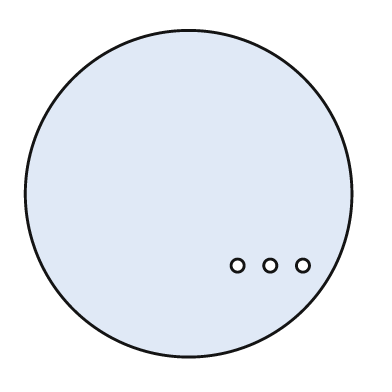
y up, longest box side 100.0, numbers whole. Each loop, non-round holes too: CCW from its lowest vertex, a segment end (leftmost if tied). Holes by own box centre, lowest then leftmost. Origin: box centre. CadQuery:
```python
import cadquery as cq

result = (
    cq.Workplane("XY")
    .moveTo(0.0, 0.0)
    .circle(50.0)
    .moveTo(15.0, -22.0)
    .circle(2.0)
    .moveTo(25.0, -22.0)
    .circle(2.0)
    .moveTo(35.0, -22.0)
    .circle(2.0)
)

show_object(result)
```